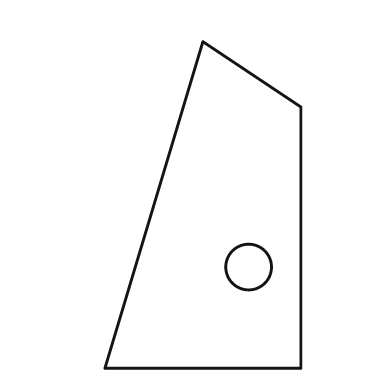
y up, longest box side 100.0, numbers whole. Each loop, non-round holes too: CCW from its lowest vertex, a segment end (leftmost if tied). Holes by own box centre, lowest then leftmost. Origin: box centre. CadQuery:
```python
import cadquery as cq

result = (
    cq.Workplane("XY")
    .moveTo(-30.0, -50.0)
    .lineTo(30.0, -50.0)
    .lineTo(30.0, 30.0)
    .lineTo(0.0, 50.0)
    .close()
    .moveTo(14.0, -19.0)
    .circle(7.0)
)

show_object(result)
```